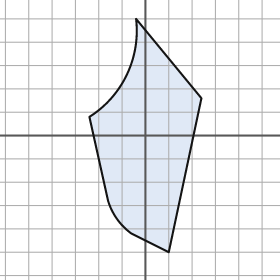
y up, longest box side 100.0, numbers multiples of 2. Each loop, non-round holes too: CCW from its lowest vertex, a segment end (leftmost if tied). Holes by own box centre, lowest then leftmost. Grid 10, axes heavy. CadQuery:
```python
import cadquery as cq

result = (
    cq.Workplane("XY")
    .moveTo(10.0, -50.0)
    .lineTo(24.0, 16.0)
    .lineTo(-4.0, 50.0)
    .threePointArc((-8.0, 26.0), (-24.0, 8.0))
    .lineTo(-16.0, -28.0)
    .threePointArc((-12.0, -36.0), (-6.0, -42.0))
    .close()
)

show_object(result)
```